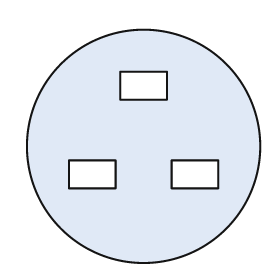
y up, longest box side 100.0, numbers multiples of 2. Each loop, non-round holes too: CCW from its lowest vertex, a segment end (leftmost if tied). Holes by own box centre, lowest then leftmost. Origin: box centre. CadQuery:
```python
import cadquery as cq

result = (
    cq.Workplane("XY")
    .moveTo(0.0, 0.0)
    .circle(50.0)
    .moveTo(-32.0, -18.0)
    .lineTo(-12.0, -18.0)
    .lineTo(-12.0, -6.0)
    .lineTo(-32.0, -6.0)
    .close()
    .moveTo(12.0, -18.0)
    .lineTo(32.0, -18.0)
    .lineTo(32.0, -6.0)
    .lineTo(12.0, -6.0)
    .close()
    .moveTo(-10.0, 20.0)
    .lineTo(10.0, 20.0)
    .lineTo(10.0, 32.0)
    .lineTo(-10.0, 32.0)
    .close()
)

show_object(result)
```